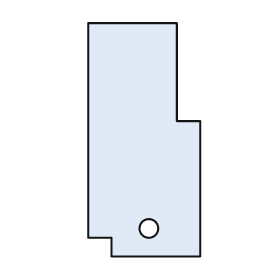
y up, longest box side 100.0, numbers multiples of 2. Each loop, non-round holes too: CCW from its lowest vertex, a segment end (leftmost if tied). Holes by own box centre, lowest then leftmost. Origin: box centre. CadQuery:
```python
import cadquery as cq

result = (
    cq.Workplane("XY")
    .moveTo(-14.0, -50.0)
    .lineTo(24.0, -50.0)
    .lineTo(24.0, 8.0)
    .lineTo(14.0, 8.0)
    .lineTo(14.0, 50.0)
    .lineTo(-24.0, 50.0)
    .lineTo(-24.0, -42.0)
    .lineTo(-14.0, -42.0)
    .close()
    .moveTo(2.0, -38.0)
    .circle(4.0)
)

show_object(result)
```